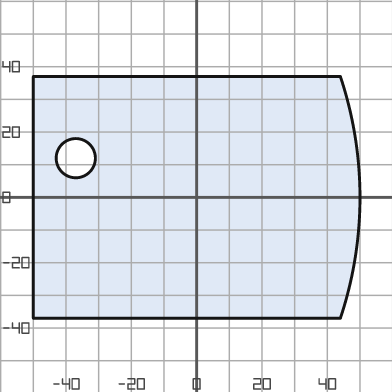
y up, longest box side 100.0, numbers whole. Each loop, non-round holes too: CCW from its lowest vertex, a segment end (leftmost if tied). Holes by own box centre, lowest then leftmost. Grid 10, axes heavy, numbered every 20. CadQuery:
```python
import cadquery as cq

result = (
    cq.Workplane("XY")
    .moveTo(-50.0, -37.0)
    .lineTo(44.0, -37.0)
    .threePointArc((50.0, 0.0), (44.0, 37.0))
    .lineTo(-50.0, 37.0)
    .close()
    .moveTo(-37.0, 12.0)
    .circle(6.0)
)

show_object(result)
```